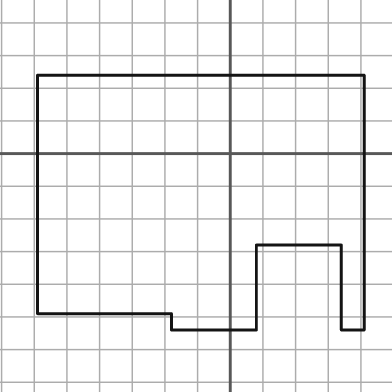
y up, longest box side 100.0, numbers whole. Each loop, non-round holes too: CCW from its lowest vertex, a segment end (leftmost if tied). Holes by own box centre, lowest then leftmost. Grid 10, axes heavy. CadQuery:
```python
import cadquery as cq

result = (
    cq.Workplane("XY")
    .moveTo(-18.0, -54.0)
    .lineTo(8.0, -54.0)
    .lineTo(8.0, -28.0)
    .lineTo(34.0, -28.0)
    .lineTo(34.0, -54.0)
    .lineTo(41.0, -54.0)
    .lineTo(41.0, 24.0)
    .lineTo(-59.0, 24.0)
    .lineTo(-59.0, -49.0)
    .lineTo(-18.0, -49.0)
    .close()
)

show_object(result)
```